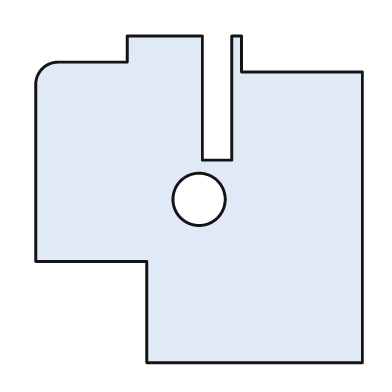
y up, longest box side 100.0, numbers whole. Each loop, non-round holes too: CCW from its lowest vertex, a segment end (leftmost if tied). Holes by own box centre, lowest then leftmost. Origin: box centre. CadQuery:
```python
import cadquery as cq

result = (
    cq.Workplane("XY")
    .moveTo(-16.0, -50.0)
    .lineTo(50.0, -50.0)
    .lineTo(50.0, 39.0)
    .lineTo(13.0, 39.0)
    .lineTo(13.0, 50.0)
    .lineTo(10.0, 50.0)
    .lineTo(10.0, 12.0)
    .lineTo(1.0, 12.0)
    .lineTo(1.0, 50.0)
    .lineTo(-22.0, 50.0)
    .lineTo(-22.0, 42.0)
    .lineTo(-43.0, 42.0)
    .threePointArc((-48.0, 40.0), (-50.0, 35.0))
    .lineTo(-50.0, -19.0)
    .lineTo(-16.0, -19.0)
    .close()
    .moveTo(0.0, 0.0)
    .circle(8.0)
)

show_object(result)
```